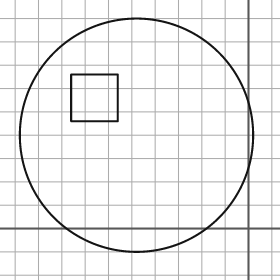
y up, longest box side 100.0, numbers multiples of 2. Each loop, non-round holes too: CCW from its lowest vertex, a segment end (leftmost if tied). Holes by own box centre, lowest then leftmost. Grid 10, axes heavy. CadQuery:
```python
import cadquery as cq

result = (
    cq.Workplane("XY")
    .moveTo(-48.0, 40.0)
    .circle(50.0)
    .moveTo(-76.0, 46.0)
    .lineTo(-56.0, 46.0)
    .lineTo(-56.0, 66.0)
    .lineTo(-76.0, 66.0)
    .close()
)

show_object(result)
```